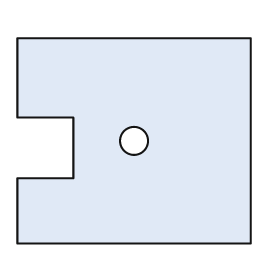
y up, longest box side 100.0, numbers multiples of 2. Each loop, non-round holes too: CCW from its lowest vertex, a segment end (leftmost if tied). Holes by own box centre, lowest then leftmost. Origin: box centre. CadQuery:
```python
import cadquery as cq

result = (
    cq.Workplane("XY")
    .moveTo(-50.0, -44.0)
    .lineTo(50.0, -44.0)
    .lineTo(50.0, 44.0)
    .lineTo(-50.0, 44.0)
    .lineTo(-50.0, 10.0)
    .lineTo(-26.0, 10.0)
    .lineTo(-26.0, -16.0)
    .lineTo(-50.0, -16.0)
    .close()
    .moveTo(0.0, 0.0)
    .circle(6.0)
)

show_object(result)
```